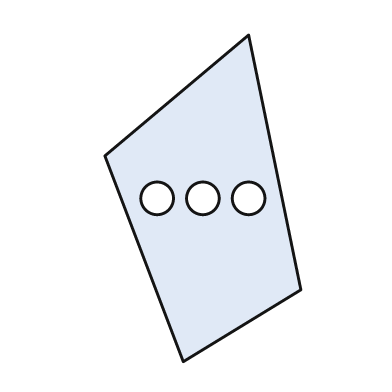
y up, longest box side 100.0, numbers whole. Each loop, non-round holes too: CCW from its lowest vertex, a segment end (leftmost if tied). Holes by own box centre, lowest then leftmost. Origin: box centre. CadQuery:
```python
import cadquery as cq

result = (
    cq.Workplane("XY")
    .moveTo(-6.0, -50.0)
    .lineTo(30.0, -28.0)
    .lineTo(14.0, 50.0)
    .lineTo(-30.0, 13.0)
    .close()
    .moveTo(-14.0, 0.0)
    .circle(5.0)
    .moveTo(0.0, 0.0)
    .circle(5.0)
    .moveTo(14.0, 0.0)
    .circle(5.0)
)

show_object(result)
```